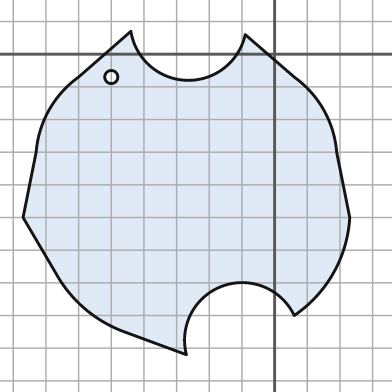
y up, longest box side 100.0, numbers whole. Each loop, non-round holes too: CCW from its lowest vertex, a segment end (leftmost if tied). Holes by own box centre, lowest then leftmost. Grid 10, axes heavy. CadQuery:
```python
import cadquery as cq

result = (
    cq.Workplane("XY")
    .moveTo(-27.0, -92.0)
    .threePointArc((-16.0, -71.0), (6.0, -80.0))
    .threePointArc((18.0, -67.0), (23.0, -50.0))
    .lineTo(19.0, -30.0)
    .threePointArc((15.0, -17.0), (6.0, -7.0))
    .lineTo(-9.0, 6.0)
    .threePointArc((-27.0, -8.0), (-44.0, 7.0))
    .lineTo(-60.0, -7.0)
    .threePointArc((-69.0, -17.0), (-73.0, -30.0))
    .lineTo(-77.0, -50.0)
    .lineTo(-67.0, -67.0)
    .threePointArc((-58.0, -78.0), (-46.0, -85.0))
    .close()
    .moveTo(-50.0, -7.0)
    .circle(2.0)
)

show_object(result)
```